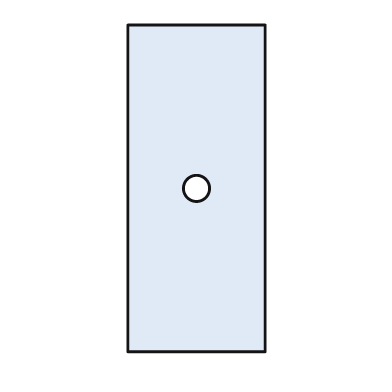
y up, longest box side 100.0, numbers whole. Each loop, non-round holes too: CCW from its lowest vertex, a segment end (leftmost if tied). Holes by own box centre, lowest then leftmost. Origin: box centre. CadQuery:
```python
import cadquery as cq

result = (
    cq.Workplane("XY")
    .moveTo(-21.0, -50.0)
    .lineTo(21.0, -50.0)
    .lineTo(21.0, 50.0)
    .lineTo(-21.0, 50.0)
    .close()
    .moveTo(0.0, 0.0)
    .circle(4.0)
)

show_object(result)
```